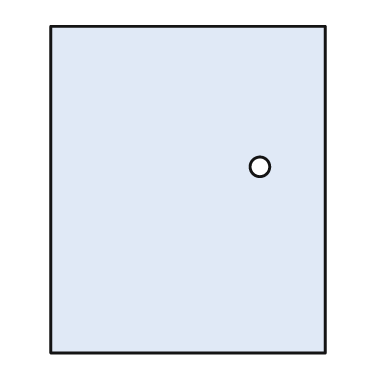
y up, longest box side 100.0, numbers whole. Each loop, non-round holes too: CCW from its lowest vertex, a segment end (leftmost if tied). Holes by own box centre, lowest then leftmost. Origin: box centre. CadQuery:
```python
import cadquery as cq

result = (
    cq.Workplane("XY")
    .moveTo(-42.0, -50.0)
    .lineTo(42.0, -50.0)
    .lineTo(42.0, 50.0)
    .lineTo(-42.0, 50.0)
    .close()
    .moveTo(22.0, 7.0)
    .circle(3.0)
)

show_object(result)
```